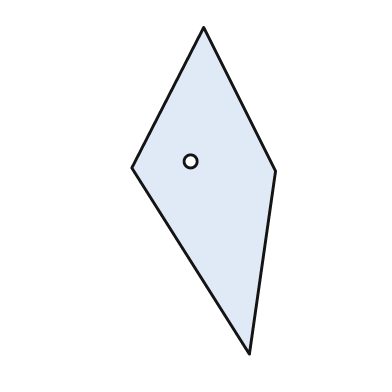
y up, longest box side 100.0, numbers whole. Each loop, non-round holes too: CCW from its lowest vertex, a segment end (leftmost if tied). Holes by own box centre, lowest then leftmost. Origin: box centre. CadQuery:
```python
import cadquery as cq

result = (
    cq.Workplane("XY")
    .moveTo(14.0, -50.0)
    .lineTo(22.0, 6.0)
    .lineTo(0.0, 50.0)
    .lineTo(-22.0, 7.0)
    .close()
    .moveTo(-4.0, 9.0)
    .circle(2.0)
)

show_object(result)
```